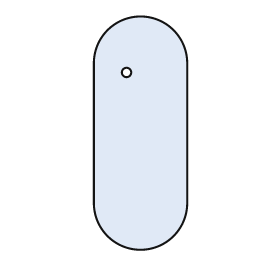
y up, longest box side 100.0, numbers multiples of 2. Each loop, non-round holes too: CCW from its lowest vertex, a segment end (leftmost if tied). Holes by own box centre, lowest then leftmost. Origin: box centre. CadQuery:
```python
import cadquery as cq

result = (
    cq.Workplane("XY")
    .moveTo(-20.0, -30.0)
    .threePointArc((0.0, -50.0), (20.0, -30.0))
    .lineTo(20.0, 30.0)
    .threePointArc((0.0, 50.0), (-20.0, 30.0))
    .close()
    .moveTo(-6.0, 26.0)
    .circle(2.0)
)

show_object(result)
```